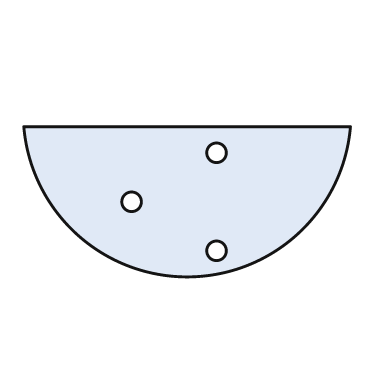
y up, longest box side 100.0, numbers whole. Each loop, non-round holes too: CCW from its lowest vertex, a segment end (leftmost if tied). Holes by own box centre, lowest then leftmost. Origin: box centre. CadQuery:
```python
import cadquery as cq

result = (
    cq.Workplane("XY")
    .moveTo(-50.0, 23.0)
    .threePointArc((0.0, -23.0), (50.0, 23.0))
    .close()
    .moveTo(9.0, -15.0)
    .circle(3.0)
    .moveTo(-17.0, 0.0)
    .circle(3.0)
    .moveTo(9.0, 15.0)
    .circle(3.0)
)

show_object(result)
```